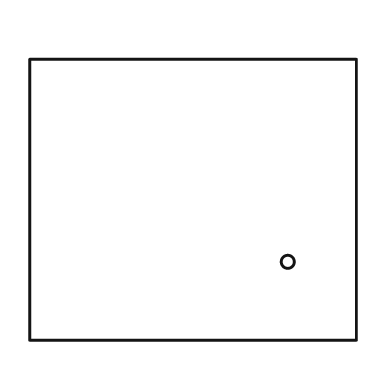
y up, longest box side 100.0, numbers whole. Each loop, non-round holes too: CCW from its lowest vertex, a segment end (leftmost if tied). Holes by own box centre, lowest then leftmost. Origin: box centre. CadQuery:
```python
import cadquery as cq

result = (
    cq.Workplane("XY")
    .moveTo(-50.0, -43.0)
    .lineTo(50.0, -43.0)
    .lineTo(50.0, 43.0)
    .lineTo(-50.0, 43.0)
    .close()
    .moveTo(29.0, -19.0)
    .circle(2.0)
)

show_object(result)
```